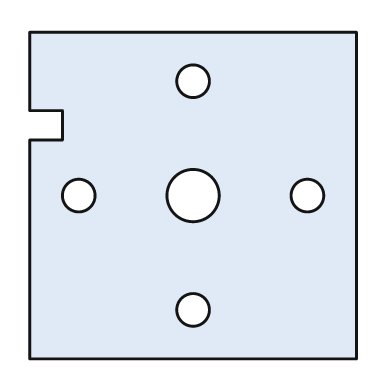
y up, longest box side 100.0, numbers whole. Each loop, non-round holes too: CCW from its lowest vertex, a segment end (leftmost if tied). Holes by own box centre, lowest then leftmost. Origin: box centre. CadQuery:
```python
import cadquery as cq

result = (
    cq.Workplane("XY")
    .moveTo(-50.0, -50.0)
    .lineTo(50.0, -50.0)
    .lineTo(50.0, 50.0)
    .lineTo(-50.0, 50.0)
    .lineTo(-50.0, 26.0)
    .lineTo(-40.0, 26.0)
    .lineTo(-40.0, 17.0)
    .lineTo(-50.0, 17.0)
    .close()
    .moveTo(0.0, -35.0)
    .circle(5.0)
    .moveTo(-35.0, 0.0)
    .circle(5.0)
    .moveTo(0.0, 0.0)
    .circle(8.0)
    .moveTo(35.0, 0.0)
    .circle(5.0)
    .moveTo(0.0, 35.0)
    .circle(5.0)
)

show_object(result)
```